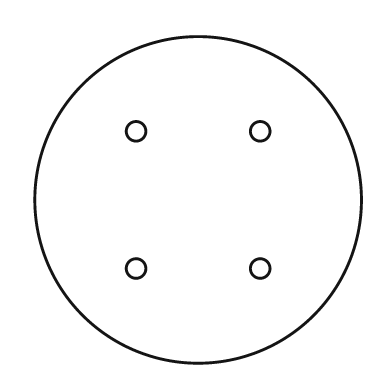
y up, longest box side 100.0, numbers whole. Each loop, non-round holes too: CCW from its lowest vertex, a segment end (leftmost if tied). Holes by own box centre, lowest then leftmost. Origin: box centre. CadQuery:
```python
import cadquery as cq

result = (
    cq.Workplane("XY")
    .moveTo(0.0, 0.0)
    .circle(50.0)
    .moveTo(-19.0, -21.0)
    .circle(3.0)
    .moveTo(19.0, -21.0)
    .circle(3.0)
    .moveTo(-19.0, 21.0)
    .circle(3.0)
    .moveTo(19.0, 21.0)
    .circle(3.0)
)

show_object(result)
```